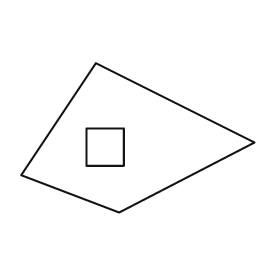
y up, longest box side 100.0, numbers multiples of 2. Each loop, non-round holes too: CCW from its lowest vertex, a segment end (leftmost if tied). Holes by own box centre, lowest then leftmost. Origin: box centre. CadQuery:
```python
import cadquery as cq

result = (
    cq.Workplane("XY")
    .moveTo(-8.0, -32.0)
    .lineTo(50.0, -2.0)
    .lineTo(-18.0, 32.0)
    .lineTo(-50.0, -16.0)
    .close()
    .moveTo(-22.0, -12.0)
    .lineTo(-6.0, -12.0)
    .lineTo(-6.0, 4.0)
    .lineTo(-22.0, 4.0)
    .close()
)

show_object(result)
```